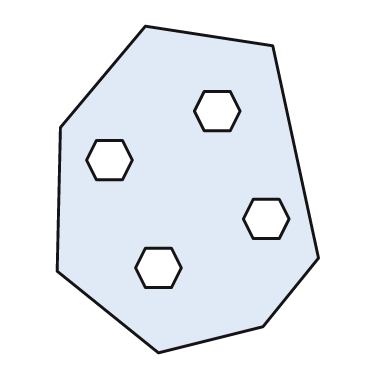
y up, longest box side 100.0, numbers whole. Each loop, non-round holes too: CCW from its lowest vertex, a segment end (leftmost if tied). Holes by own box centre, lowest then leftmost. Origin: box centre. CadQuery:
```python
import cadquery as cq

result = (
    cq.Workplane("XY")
    .moveTo(-9.0, -50.0)
    .lineTo(23.0, -42.0)
    .lineTo(40.0, -21.0)
    .lineTo(26.0, 44.0)
    .lineTo(-13.0, 50.0)
    .lineTo(-39.0, 19.0)
    .lineTo(-40.0, -25.0)
    .close()
    .moveTo(-13.0, -30.0)
    .lineTo(-5.0, -30.0)
    .lineTo(-2.0, -24.0)
    .lineTo(-5.0, -18.0)
    .lineTo(-13.0, -18.0)
    .lineTo(-16.0, -24.0)
    .close()
    .moveTo(20.0, -15.0)
    .lineTo(28.0, -15.0)
    .lineTo(31.0, -9.0)
    .lineTo(28.0, -3.0)
    .lineTo(20.0, -3.0)
    .lineTo(17.0, -9.0)
    .close()
    .moveTo(-28.0, 3.0)
    .lineTo(-20.0, 3.0)
    .lineTo(-17.0, 9.0)
    .lineTo(-20.0, 15.0)
    .lineTo(-28.0, 15.0)
    .lineTo(-31.0, 9.0)
    .close()
    .moveTo(5.0, 18.0)
    .lineTo(13.0, 18.0)
    .lineTo(16.0, 24.0)
    .lineTo(13.0, 30.0)
    .lineTo(5.0, 30.0)
    .lineTo(2.0, 24.0)
    .close()
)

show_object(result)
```